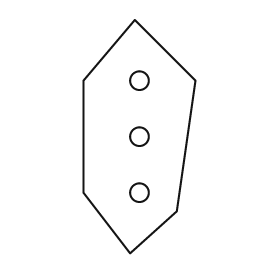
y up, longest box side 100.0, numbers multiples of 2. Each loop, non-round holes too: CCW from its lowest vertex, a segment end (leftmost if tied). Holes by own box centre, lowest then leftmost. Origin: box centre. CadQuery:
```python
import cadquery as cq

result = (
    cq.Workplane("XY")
    .moveTo(-4.0, -50.0)
    .lineTo(16.0, -32.0)
    .lineTo(24.0, 24.0)
    .lineTo(-2.0, 50.0)
    .lineTo(-24.0, 24.0)
    .lineTo(-24.0, -24.0)
    .close()
    .moveTo(0.0, -24.0)
    .circle(4.0)
    .moveTo(0.0, 0.0)
    .circle(4.0)
    .moveTo(0.0, 24.0)
    .circle(4.0)
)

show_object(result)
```